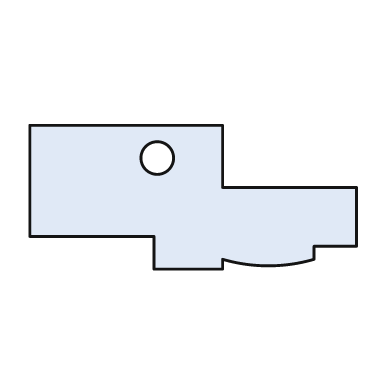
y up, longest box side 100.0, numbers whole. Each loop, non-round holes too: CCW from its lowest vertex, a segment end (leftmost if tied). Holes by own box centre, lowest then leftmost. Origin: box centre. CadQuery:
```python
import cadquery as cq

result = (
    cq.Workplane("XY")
    .moveTo(-12.0, -22.0)
    .lineTo(9.0, -22.0)
    .lineTo(9.0, -19.0)
    .threePointArc((23.0, -21.0), (37.0, -19.0))
    .lineTo(37.0, -15.0)
    .lineTo(50.0, -15.0)
    .lineTo(50.0, 3.0)
    .lineTo(9.0, 3.0)
    .lineTo(9.0, 22.0)
    .lineTo(-50.0, 22.0)
    .lineTo(-50.0, -12.0)
    .lineTo(-12.0, -12.0)
    .close()
    .moveTo(-11.0, 12.0)
    .circle(5.0)
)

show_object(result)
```